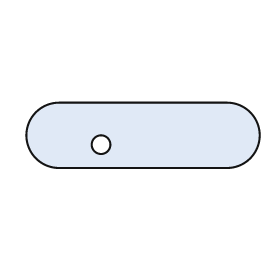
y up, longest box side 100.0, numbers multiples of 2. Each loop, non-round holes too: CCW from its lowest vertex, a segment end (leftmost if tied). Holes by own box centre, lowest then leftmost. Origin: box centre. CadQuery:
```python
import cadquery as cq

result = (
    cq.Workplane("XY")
    .moveTo(-36.0, -14.0)
    .lineTo(36.0, -14.0)
    .threePointArc((50.0, 0.0), (36.0, 14.0))
    .lineTo(-36.0, 14.0)
    .threePointArc((-50.0, 0.0), (-36.0, -14.0))
    .close()
    .moveTo(-18.0, -4.0)
    .circle(4.0)
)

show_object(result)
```